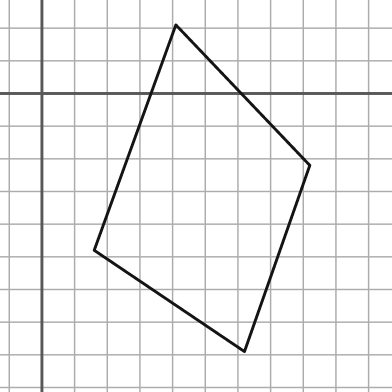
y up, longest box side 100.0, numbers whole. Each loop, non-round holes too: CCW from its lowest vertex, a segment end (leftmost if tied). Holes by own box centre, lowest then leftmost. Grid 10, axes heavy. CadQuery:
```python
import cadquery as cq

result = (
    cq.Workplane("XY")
    .moveTo(62.0, -79.0)
    .lineTo(82.0, -22.0)
    .lineTo(41.0, 21.0)
    .lineTo(16.0, -48.0)
    .close()
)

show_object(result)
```